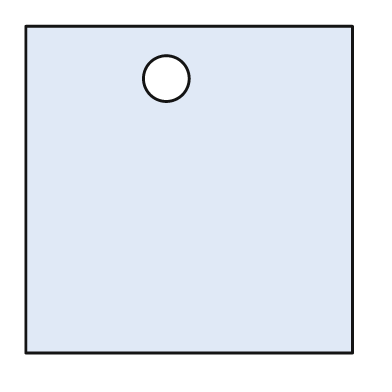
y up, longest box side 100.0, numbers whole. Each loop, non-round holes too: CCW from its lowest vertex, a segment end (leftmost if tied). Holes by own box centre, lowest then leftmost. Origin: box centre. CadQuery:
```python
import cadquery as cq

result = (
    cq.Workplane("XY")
    .moveTo(-50.0, -50.0)
    .lineTo(50.0, -50.0)
    .lineTo(50.0, 50.0)
    .lineTo(-50.0, 50.0)
    .close()
    .moveTo(-7.0, 34.0)
    .circle(7.0)
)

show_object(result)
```